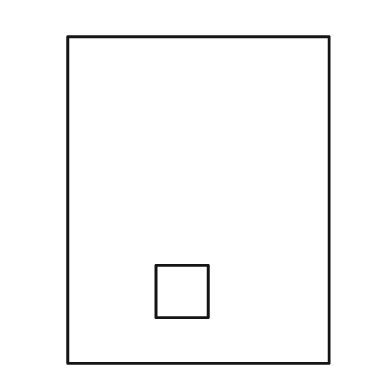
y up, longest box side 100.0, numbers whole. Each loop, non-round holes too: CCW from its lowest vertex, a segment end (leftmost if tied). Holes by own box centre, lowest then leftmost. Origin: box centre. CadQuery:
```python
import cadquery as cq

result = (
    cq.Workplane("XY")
    .moveTo(-40.0, -50.0)
    .lineTo(40.0, -50.0)
    .lineTo(40.0, 50.0)
    .lineTo(-40.0, 50.0)
    .close()
    .moveTo(-13.0, -36.0)
    .lineTo(3.0, -36.0)
    .lineTo(3.0, -20.0)
    .lineTo(-13.0, -20.0)
    .close()
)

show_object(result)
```